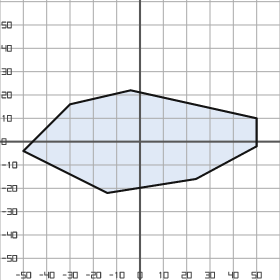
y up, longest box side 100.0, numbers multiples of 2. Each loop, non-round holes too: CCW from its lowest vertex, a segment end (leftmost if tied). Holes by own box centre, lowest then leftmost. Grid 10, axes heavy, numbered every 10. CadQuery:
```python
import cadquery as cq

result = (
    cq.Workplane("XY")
    .moveTo(-14.0, -22.0)
    .lineTo(24.0, -16.0)
    .lineTo(50.0, -2.0)
    .lineTo(50.0, 10.0)
    .lineTo(-4.0, 22.0)
    .lineTo(-30.0, 16.0)
    .lineTo(-50.0, -4.0)
    .close()
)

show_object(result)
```